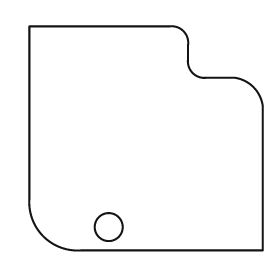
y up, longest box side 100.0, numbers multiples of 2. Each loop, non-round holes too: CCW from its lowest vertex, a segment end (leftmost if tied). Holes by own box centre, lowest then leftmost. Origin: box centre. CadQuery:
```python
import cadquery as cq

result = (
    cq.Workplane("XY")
    .moveTo(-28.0, -48.0)
    .lineTo(50.0, -48.0)
    .lineTo(50.0, 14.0)
    .threePointArc((46.0, 22.0), (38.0, 26.0))
    .lineTo(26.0, 26.0)
    .threePointArc((20.0, 28.0), (18.0, 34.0))
    .lineTo(18.0, 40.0)
    .threePointArc((16.0, 46.0), (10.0, 48.0))
    .lineTo(-50.0, 48.0)
    .lineTo(-50.0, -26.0)
    .threePointArc((-44.0, -42.0), (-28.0, -48.0))
    .close()
    .moveTo(-16.0, -38.0)
    .circle(6.0)
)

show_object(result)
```